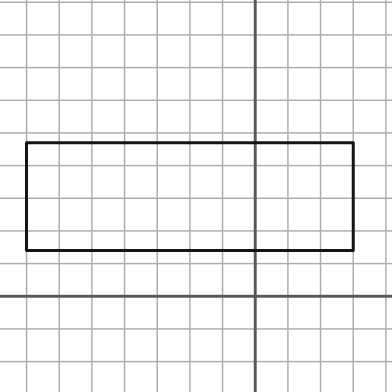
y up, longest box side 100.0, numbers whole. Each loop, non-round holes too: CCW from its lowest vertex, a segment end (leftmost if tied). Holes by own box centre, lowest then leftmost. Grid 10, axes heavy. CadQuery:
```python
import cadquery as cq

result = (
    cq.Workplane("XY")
    .moveTo(-70.0, 14.0)
    .lineTo(30.0, 14.0)
    .lineTo(30.0, 47.0)
    .lineTo(-70.0, 47.0)
    .close()
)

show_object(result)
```